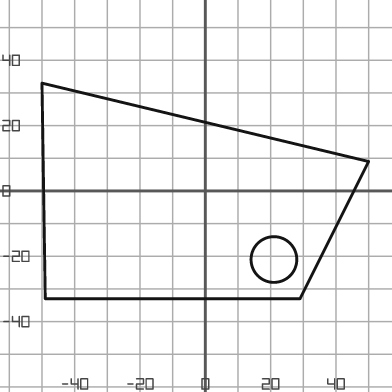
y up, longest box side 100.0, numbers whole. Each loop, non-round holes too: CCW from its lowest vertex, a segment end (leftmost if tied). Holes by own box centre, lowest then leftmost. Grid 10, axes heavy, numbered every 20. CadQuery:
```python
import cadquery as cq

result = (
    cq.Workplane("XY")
    .moveTo(-49.0, -33.0)
    .lineTo(29.0, -33.0)
    .lineTo(50.0, 9.0)
    .lineTo(-50.0, 33.0)
    .close()
    .moveTo(21.0, -21.0)
    .circle(7.0)
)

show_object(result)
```